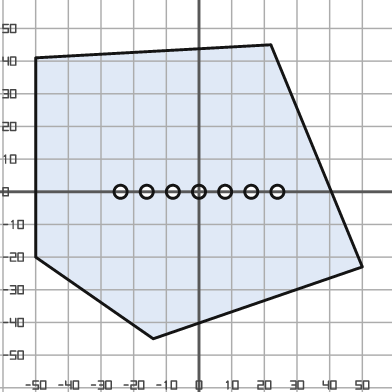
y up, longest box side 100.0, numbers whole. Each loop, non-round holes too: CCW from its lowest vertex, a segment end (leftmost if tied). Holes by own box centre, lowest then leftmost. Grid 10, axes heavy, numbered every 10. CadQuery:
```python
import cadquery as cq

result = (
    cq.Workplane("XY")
    .moveTo(-14.0, -45.0)
    .lineTo(50.0, -23.0)
    .lineTo(22.0, 45.0)
    .lineTo(-50.0, 41.0)
    .lineTo(-50.0, -20.0)
    .close()
    .moveTo(-24.0, 0.0)
    .circle(2.0)
    .moveTo(-16.0, 0.0)
    .circle(2.0)
    .moveTo(-8.0, 0.0)
    .circle(2.0)
    .moveTo(0.0, 0.0)
    .circle(2.0)
    .moveTo(8.0, 0.0)
    .circle(2.0)
    .moveTo(16.0, 0.0)
    .circle(2.0)
    .moveTo(24.0, 0.0)
    .circle(2.0)
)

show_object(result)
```